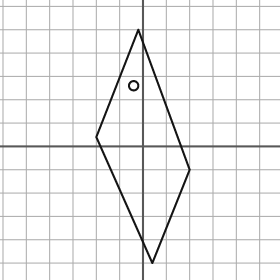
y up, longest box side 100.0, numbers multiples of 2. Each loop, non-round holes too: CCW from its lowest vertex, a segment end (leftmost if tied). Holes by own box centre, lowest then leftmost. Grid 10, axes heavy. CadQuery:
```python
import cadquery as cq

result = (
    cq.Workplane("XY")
    .moveTo(4.0, -50.0)
    .lineTo(20.0, -10.0)
    .lineTo(-2.0, 50.0)
    .lineTo(-20.0, 4.0)
    .close()
    .moveTo(-4.0, 26.0)
    .circle(2.0)
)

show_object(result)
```